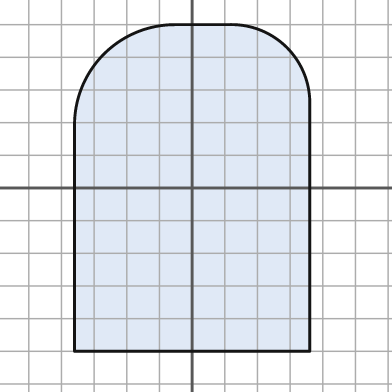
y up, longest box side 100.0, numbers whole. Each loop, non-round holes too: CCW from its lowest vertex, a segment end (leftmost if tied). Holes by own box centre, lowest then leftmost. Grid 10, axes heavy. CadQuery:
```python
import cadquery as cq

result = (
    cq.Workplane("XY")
    .moveTo(-36.0, -50.0)
    .lineTo(36.0, -50.0)
    .lineTo(36.0, 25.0)
    .threePointArc((29.0, 43.0), (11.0, 50.0))
    .lineTo(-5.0, 50.0)
    .threePointArc((-27.0, 41.0), (-36.0, 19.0))
    .close()
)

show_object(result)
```